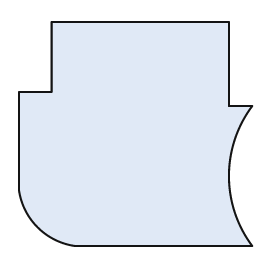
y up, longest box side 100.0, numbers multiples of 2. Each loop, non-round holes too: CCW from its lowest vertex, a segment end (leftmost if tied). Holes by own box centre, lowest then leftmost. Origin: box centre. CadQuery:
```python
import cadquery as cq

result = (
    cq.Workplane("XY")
    .moveTo(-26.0, -48.0)
    .lineTo(50.0, -48.0)
    .threePointArc((40.0, -18.0), (50.0, 12.0))
    .lineTo(40.0, 12.0)
    .lineTo(40.0, 48.0)
    .lineTo(-36.0, 48.0)
    .lineTo(-36.0, 18.0)
    .lineTo(-50.0, 18.0)
    .lineTo(-50.0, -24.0)
    .threePointArc((-42.0, -40.0), (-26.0, -48.0))
    .close()
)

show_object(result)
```